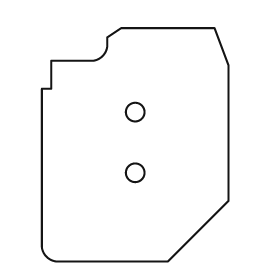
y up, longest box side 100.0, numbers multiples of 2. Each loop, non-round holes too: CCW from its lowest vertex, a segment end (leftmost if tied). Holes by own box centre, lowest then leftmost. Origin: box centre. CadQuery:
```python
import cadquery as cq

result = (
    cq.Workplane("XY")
    .moveTo(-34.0, -50.0)
    .lineTo(14.0, -50.0)
    .lineTo(40.0, -24.0)
    .lineTo(40.0, 34.0)
    .lineTo(34.0, 50.0)
    .lineTo(-6.0, 50.0)
    .lineTo(-12.0, 46.0)
    .lineTo(-12.0, 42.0)
    .threePointArc((-14.0, 38.0), (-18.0, 36.0))
    .lineTo(-36.0, 36.0)
    .lineTo(-36.0, 24.0)
    .lineTo(-40.0, 24.0)
    .lineTo(-40.0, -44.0)
    .threePointArc((-38.0, -48.0), (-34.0, -50.0))
    .close()
    .moveTo(0.0, -12.0)
    .circle(4.0)
    .moveTo(0.0, 14.0)
    .circle(4.0)
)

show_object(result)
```